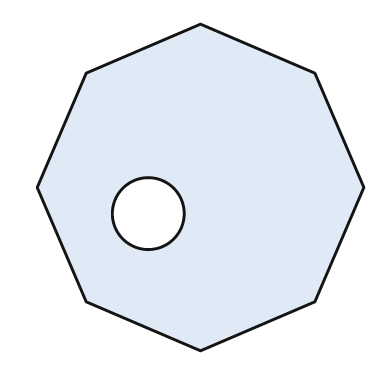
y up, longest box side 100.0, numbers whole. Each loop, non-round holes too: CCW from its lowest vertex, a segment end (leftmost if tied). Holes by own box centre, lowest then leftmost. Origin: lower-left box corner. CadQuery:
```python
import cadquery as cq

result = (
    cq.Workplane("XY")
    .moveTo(50.0, 0.0)
    .lineTo(85.0, 15.0)
    .lineTo(100.0, 50.0)
    .lineTo(85.0, 85.0)
    .lineTo(50.0, 100.0)
    .lineTo(15.0, 85.0)
    .lineTo(0.0, 50.0)
    .lineTo(15.0, 15.0)
    .close()
    .moveTo(34.0, 42.0)
    .circle(11.0)
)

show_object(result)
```